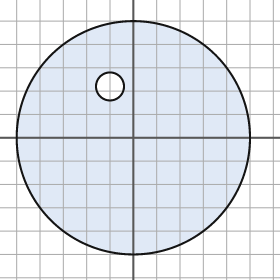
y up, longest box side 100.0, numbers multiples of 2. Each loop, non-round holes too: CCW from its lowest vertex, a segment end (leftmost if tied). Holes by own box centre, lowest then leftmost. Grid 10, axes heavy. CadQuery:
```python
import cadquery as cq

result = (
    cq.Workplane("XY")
    .moveTo(0.0, 0.0)
    .circle(50.0)
    .moveTo(-10.0, 22.0)
    .circle(6.0)
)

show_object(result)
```